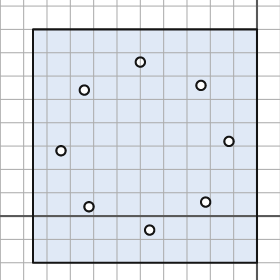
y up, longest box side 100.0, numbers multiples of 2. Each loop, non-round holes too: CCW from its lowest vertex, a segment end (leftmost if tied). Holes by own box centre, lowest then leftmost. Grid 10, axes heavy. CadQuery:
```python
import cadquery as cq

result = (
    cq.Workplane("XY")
    .moveTo(-96.0, -20.0)
    .lineTo(0.0, -20.0)
    .lineTo(0.0, 80.0)
    .lineTo(-96.0, 80.0)
    .close()
    .moveTo(-46.0, -6.0)
    .circle(2.0)
    .moveTo(-72.0, 4.0)
    .circle(2.0)
    .moveTo(-22.0, 6.0)
    .circle(2.0)
    .moveTo(-84.0, 28.0)
    .circle(2.0)
    .moveTo(-12.0, 32.0)
    .circle(2.0)
    .moveTo(-74.0, 54.0)
    .circle(2.0)
    .moveTo(-24.0, 56.0)
    .circle(2.0)
    .moveTo(-50.0, 66.0)
    .circle(2.0)
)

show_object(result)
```